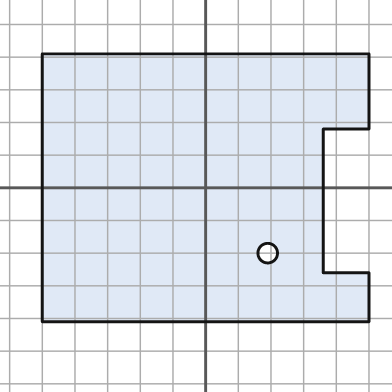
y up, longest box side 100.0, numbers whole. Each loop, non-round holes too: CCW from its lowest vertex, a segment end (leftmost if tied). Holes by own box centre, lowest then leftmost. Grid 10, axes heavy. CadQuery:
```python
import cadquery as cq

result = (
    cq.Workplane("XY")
    .moveTo(-50.0, -41.0)
    .lineTo(50.0, -41.0)
    .lineTo(50.0, -26.0)
    .lineTo(36.0, -26.0)
    .lineTo(36.0, 18.0)
    .lineTo(50.0, 18.0)
    .lineTo(50.0, 41.0)
    .lineTo(-50.0, 41.0)
    .close()
    .moveTo(19.0, -20.0)
    .circle(3.0)
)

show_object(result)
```